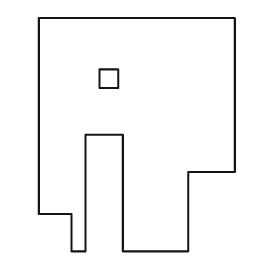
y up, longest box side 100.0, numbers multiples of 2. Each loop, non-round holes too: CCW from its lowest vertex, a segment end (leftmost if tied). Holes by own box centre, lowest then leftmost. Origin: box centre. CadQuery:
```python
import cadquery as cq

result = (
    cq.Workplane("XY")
    .moveTo(-28.0, -50.0)
    .lineTo(-22.0, -50.0)
    .lineTo(-22.0, 0.0)
    .lineTo(-6.0, 0.0)
    .lineTo(-6.0, -50.0)
    .lineTo(22.0, -50.0)
    .lineTo(22.0, -16.0)
    .lineTo(42.0, -16.0)
    .lineTo(42.0, 50.0)
    .lineTo(-42.0, 50.0)
    .lineTo(-42.0, -34.0)
    .lineTo(-28.0, -34.0)
    .close()
    .moveTo(-16.0, 20.0)
    .lineTo(-8.0, 20.0)
    .lineTo(-8.0, 28.0)
    .lineTo(-16.0, 28.0)
    .close()
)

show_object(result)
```